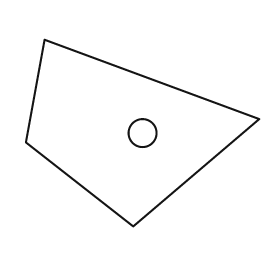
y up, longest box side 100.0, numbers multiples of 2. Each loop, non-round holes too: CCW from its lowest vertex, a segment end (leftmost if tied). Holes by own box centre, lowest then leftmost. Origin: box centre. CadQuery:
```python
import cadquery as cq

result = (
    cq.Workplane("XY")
    .moveTo(-4.0, -40.0)
    .lineTo(50.0, 6.0)
    .lineTo(-42.0, 40.0)
    .lineTo(-50.0, -4.0)
    .close()
    .moveTo(0.0, 0.0)
    .circle(6.0)
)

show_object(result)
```